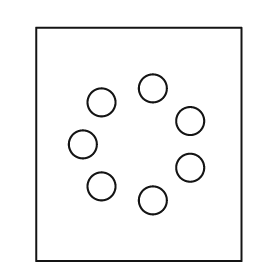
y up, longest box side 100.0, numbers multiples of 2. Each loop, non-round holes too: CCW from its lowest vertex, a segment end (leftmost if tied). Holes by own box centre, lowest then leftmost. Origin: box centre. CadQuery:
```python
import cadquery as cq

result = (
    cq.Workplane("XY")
    .moveTo(-44.0, -50.0)
    .lineTo(44.0, -50.0)
    .lineTo(44.0, 50.0)
    .lineTo(-44.0, 50.0)
    .close()
    .moveTo(6.0, -24.0)
    .circle(6.0)
    .moveTo(-16.0, -18.0)
    .circle(6.0)
    .moveTo(22.0, -10.0)
    .circle(6.0)
    .moveTo(-24.0, 0.0)
    .circle(6.0)
    .moveTo(22.0, 10.0)
    .circle(6.0)
    .moveTo(-16.0, 18.0)
    .circle(6.0)
    .moveTo(6.0, 24.0)
    .circle(6.0)
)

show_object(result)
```